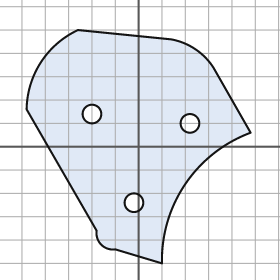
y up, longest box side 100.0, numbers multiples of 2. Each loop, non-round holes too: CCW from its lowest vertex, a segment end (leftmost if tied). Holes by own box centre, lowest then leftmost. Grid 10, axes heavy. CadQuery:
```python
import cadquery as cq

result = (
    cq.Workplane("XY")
    .moveTo(10.0, -50.0)
    .threePointArc((20.0, -16.0), (48.0, 6.0))
    .lineTo(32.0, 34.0)
    .threePointArc((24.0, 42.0), (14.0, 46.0))
    .lineTo(-26.0, 50.0)
    .threePointArc((-42.0, 36.0), (-48.0, 16.0))
    .lineTo(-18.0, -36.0)
    .threePointArc((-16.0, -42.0), (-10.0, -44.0))
    .close()
    .moveTo(-2.0, -24.0)
    .circle(4.0)
    .moveTo(22.0, 10.0)
    .circle(4.0)
    .moveTo(-20.0, 14.0)
    .circle(4.0)
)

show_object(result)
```